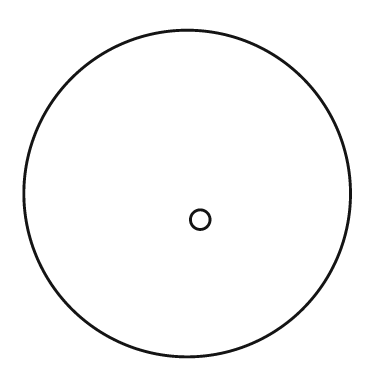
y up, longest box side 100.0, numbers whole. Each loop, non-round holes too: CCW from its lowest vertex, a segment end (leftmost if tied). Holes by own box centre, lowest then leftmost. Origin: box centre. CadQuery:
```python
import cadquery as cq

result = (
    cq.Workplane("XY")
    .moveTo(0.0, 0.0)
    .circle(50.0)
    .moveTo(4.0, -8.0)
    .circle(3.0)
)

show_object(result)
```